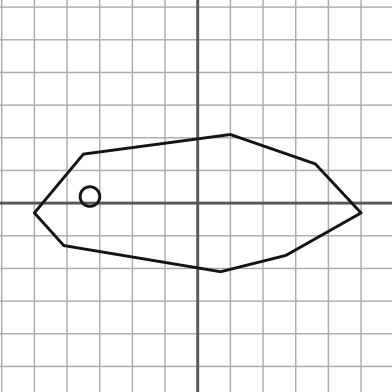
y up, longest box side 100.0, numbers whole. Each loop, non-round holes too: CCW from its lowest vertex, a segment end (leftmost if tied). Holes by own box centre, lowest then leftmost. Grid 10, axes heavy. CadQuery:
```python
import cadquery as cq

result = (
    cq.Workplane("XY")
    .moveTo(7.0, -21.0)
    .lineTo(27.0, -16.0)
    .lineTo(50.0, -3.0)
    .lineTo(36.0, 12.0)
    .lineTo(10.0, 21.0)
    .lineTo(-35.0, 15.0)
    .lineTo(-50.0, -3.0)
    .lineTo(-41.0, -13.0)
    .close()
    .moveTo(-33.0, 2.0)
    .circle(3.0)
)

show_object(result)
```